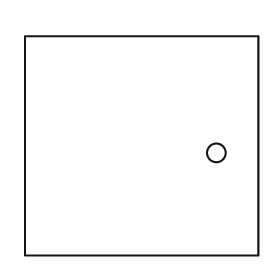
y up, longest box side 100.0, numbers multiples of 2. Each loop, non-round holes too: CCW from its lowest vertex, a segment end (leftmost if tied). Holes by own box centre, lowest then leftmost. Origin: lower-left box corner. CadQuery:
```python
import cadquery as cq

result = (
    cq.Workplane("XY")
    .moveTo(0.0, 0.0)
    .lineTo(100.0, 0.0)
    .lineTo(100.0, 94.0)
    .lineTo(0.0, 94.0)
    .close()
    .moveTo(82.0, 44.0)
    .circle(4.0)
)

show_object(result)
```